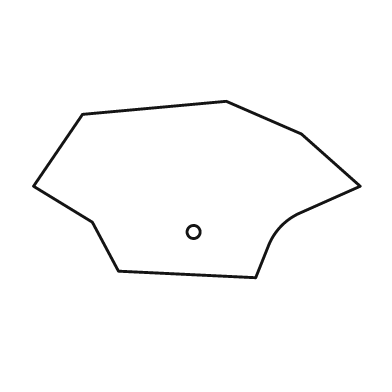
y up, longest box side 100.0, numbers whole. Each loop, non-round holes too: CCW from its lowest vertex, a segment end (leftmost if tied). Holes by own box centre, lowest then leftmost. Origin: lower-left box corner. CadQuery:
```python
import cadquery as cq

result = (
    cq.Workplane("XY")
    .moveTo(68.0, 0.0)
    .lineTo(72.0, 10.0)
    .threePointArc((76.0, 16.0), (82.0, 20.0))
    .lineTo(100.0, 28.0)
    .lineTo(82.0, 44.0)
    .lineTo(59.0, 54.0)
    .lineTo(15.0, 50.0)
    .lineTo(0.0, 28.0)
    .lineTo(18.0, 17.0)
    .lineTo(26.0, 2.0)
    .close()
    .moveTo(49.0, 14.0)
    .circle(2.0)
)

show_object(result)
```